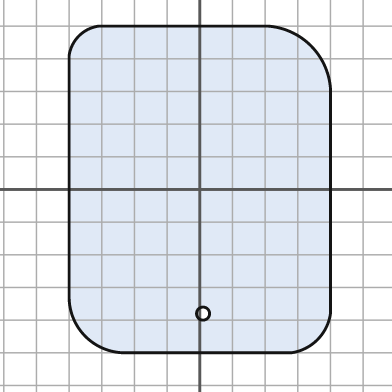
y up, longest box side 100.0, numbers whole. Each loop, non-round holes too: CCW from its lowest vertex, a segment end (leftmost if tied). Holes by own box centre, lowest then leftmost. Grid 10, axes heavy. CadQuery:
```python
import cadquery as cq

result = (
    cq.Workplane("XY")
    .moveTo(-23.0, -50.0)
    .lineTo(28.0, -50.0)
    .threePointArc((36.0, -46.0), (40.0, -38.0))
    .lineTo(40.0, 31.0)
    .threePointArc((34.0, 44.0), (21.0, 50.0))
    .lineTo(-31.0, 50.0)
    .threePointArc((-37.0, 47.0), (-40.0, 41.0))
    .lineTo(-40.0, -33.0)
    .threePointArc((-35.0, -45.0), (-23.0, -50.0))
    .close()
    .moveTo(1.0, -38.0)
    .circle(2.0)
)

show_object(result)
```